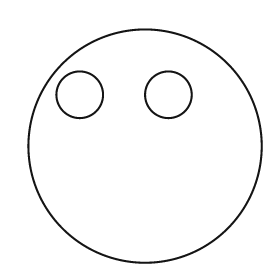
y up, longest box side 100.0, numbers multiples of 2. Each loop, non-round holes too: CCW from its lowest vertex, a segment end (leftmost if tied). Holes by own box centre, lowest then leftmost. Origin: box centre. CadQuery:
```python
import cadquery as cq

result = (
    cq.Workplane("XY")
    .moveTo(0.0, 0.0)
    .circle(50.0)
    .moveTo(-28.0, 22.0)
    .circle(10.0)
    .moveTo(10.0, 22.0)
    .circle(10.0)
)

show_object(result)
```